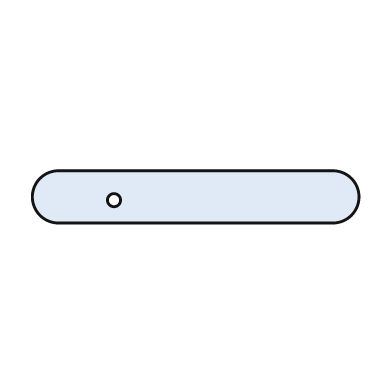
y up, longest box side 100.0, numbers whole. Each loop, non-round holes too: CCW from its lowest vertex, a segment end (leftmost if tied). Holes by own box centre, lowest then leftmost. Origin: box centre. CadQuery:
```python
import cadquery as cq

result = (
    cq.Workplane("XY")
    .moveTo(-42.0, -8.0)
    .lineTo(42.0, -8.0)
    .threePointArc((50.0, 0.0), (42.0, 8.0))
    .lineTo(-42.0, 8.0)
    .threePointArc((-50.0, 0.0), (-42.0, -8.0))
    .close()
    .moveTo(-25.0, -1.0)
    .circle(2.0)
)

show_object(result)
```